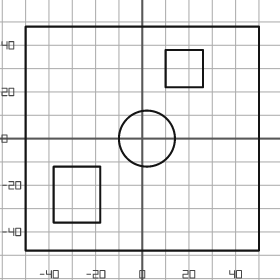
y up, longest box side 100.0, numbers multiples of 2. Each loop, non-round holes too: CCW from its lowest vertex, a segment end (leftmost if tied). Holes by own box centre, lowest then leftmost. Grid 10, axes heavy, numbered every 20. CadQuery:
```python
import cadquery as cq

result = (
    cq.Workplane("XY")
    .moveTo(-50.0, -48.0)
    .lineTo(50.0, -48.0)
    .lineTo(50.0, 48.0)
    .lineTo(-50.0, 48.0)
    .close()
    .moveTo(-38.0, -36.0)
    .lineTo(-18.0, -36.0)
    .lineTo(-18.0, -12.0)
    .lineTo(-38.0, -12.0)
    .close()
    .moveTo(2.0, 0.0)
    .circle(12.0)
    .moveTo(10.0, 22.0)
    .lineTo(26.0, 22.0)
    .lineTo(26.0, 38.0)
    .lineTo(10.0, 38.0)
    .close()
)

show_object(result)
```